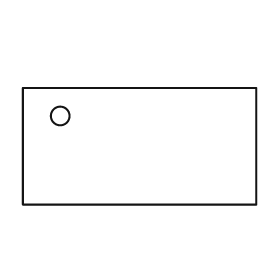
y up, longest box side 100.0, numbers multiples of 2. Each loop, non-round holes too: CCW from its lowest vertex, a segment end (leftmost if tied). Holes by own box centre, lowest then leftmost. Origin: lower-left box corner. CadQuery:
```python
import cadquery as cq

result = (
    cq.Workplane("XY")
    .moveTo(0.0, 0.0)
    .lineTo(100.0, 0.0)
    .lineTo(100.0, 50.0)
    .lineTo(0.0, 50.0)
    .close()
    .moveTo(16.0, 38.0)
    .circle(4.0)
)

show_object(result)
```